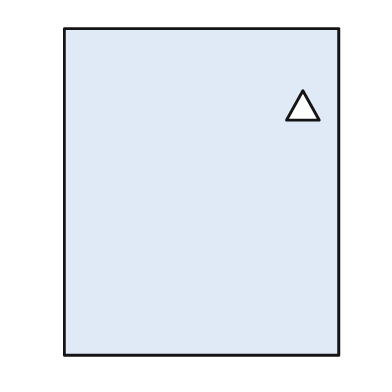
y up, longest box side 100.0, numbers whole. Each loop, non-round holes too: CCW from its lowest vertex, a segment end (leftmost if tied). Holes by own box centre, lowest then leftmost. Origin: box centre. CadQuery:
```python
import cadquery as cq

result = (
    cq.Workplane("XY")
    .moveTo(-42.0, -50.0)
    .lineTo(42.0, -50.0)
    .lineTo(42.0, 50.0)
    .lineTo(-42.0, 50.0)
    .close()
    .moveTo(26.0, 22.0)
    .lineTo(36.0, 22.0)
    .lineTo(31.0, 31.0)
    .close()
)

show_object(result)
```